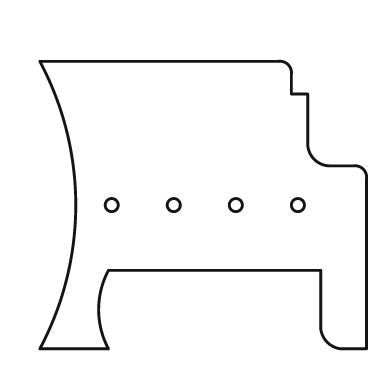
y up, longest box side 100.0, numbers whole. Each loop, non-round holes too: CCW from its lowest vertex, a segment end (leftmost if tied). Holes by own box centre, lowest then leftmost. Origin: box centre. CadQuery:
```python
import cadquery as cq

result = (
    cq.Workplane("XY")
    .moveTo(-50.0, -44.0)
    .lineTo(-29.0, -44.0)
    .threePointArc((-32.0, -32.0), (-29.0, -20.0))
    .lineTo(36.0, -20.0)
    .lineTo(36.0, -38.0)
    .threePointArc((38.0, -42.0), (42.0, -44.0))
    .lineTo(50.0, -44.0)
    .lineTo(50.0, 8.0)
    .threePointArc((49.0, 11.0), (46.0, 12.0))
    .lineTo(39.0, 12.0)
    .threePointArc((34.0, 14.0), (32.0, 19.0))
    .lineTo(32.0, 34.0)
    .lineTo(27.0, 34.0)
    .lineTo(27.0, 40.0)
    .threePointArc((26.0, 43.0), (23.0, 44.0))
    .lineTo(-50.0, 44.0)
    .threePointArc((-39.0, 0.0), (-50.0, -44.0))
    .close()
    .moveTo(-28.0, 0.0)
    .circle(2.0)
    .moveTo(-9.0, 0.0)
    .circle(2.0)
    .moveTo(10.0, 0.0)
    .circle(2.0)
    .moveTo(29.0, 0.0)
    .circle(2.0)
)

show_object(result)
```